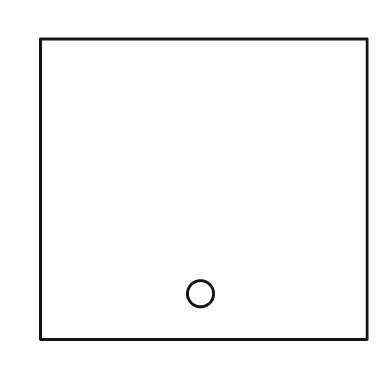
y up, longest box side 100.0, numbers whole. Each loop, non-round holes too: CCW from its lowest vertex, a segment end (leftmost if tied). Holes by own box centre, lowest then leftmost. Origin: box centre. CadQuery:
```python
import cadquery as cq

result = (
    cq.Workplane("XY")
    .moveTo(-50.0, -46.0)
    .lineTo(50.0, -46.0)
    .lineTo(50.0, 46.0)
    .lineTo(-50.0, 46.0)
    .close()
    .moveTo(-1.0, -32.0)
    .circle(4.0)
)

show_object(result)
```